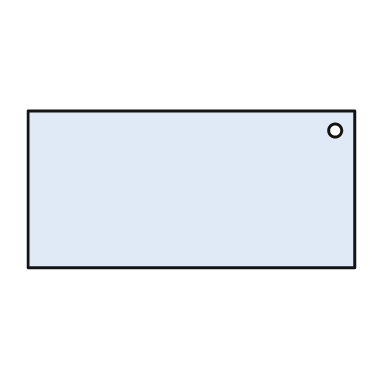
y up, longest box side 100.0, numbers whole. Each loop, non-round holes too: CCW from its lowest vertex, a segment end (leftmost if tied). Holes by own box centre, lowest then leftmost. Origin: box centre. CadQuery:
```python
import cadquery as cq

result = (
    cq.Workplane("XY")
    .moveTo(-50.0, -24.0)
    .lineTo(50.0, -24.0)
    .lineTo(50.0, 24.0)
    .lineTo(-50.0, 24.0)
    .close()
    .moveTo(44.0, 18.0)
    .circle(2.0)
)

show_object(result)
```